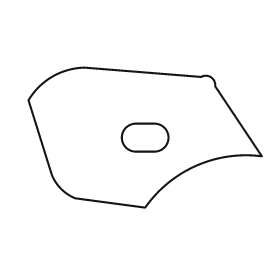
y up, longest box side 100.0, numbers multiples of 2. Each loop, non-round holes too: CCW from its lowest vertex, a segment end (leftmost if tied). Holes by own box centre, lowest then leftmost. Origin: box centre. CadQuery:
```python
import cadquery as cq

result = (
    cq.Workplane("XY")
    .moveTo(0.0, -30.0)
    .threePointArc((22.0, -12.0), (50.0, -8.0))
    .lineTo(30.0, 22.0)
    .threePointArc((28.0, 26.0), (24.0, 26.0))
    .lineTo(-26.0, 30.0)
    .threePointArc((-40.0, 26.0), (-50.0, 16.0))
    .lineTo(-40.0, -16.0)
    .threePointArc((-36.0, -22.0), (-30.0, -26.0))
    .close()
    .moveTo(-4.0, -6.0)
    .lineTo(4.0, -6.0)
    .threePointArc((10.0, 0.0), (4.0, 6.0))
    .lineTo(-4.0, 6.0)
    .threePointArc((-10.0, 0.0), (-4.0, -6.0))
    .close()
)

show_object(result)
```